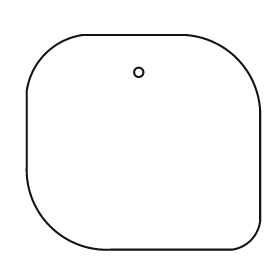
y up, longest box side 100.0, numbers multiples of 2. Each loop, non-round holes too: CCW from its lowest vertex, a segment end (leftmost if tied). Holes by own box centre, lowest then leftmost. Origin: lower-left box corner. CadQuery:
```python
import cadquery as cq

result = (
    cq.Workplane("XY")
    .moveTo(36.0, 0.0)
    .lineTo(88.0, 0.0)
    .threePointArc((96.0, 4.0), (100.0, 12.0))
    .lineTo(100.0, 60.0)
    .threePointArc((90.0, 82.0), (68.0, 92.0))
    .lineTo(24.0, 92.0)
    .threePointArc((8.0, 84.0), (0.0, 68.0))
    .lineTo(0.0, 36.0)
    .threePointArc((10.0, 10.0), (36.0, 0.0))
    .close()
    .moveTo(48.0, 76.0)
    .circle(2.0)
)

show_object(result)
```